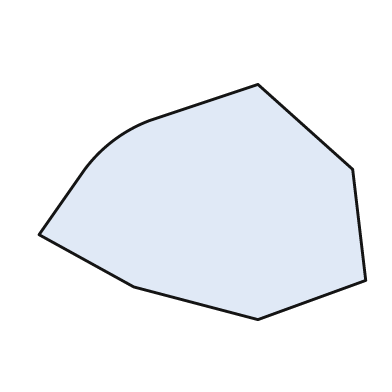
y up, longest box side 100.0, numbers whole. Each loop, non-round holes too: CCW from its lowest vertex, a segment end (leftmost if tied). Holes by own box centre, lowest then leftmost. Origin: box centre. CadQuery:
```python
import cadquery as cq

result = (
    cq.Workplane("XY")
    .moveTo(17.0, -36.0)
    .lineTo(50.0, -24.0)
    .lineTo(46.0, 10.0)
    .lineTo(17.0, 36.0)
    .lineTo(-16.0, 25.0)
    .threePointArc((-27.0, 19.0), (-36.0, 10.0))
    .lineTo(-50.0, -10.0)
    .lineTo(-21.0, -26.0)
    .close()
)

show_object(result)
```